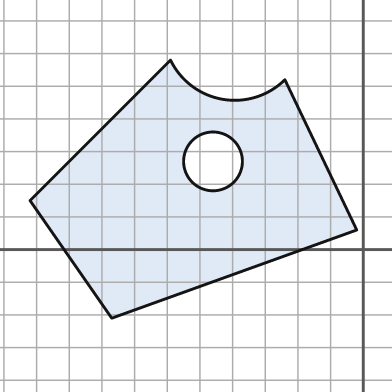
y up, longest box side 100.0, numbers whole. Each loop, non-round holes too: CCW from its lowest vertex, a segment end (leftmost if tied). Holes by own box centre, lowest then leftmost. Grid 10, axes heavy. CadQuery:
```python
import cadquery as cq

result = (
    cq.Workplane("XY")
    .moveTo(-77.0, -21.0)
    .lineTo(-2.0, 6.0)
    .lineTo(-24.0, 52.0)
    .threePointArc((-43.0, 46.0), (-59.0, 58.0))
    .lineTo(-102.0, 15.0)
    .close()
    .moveTo(-46.0, 27.0)
    .circle(9.0)
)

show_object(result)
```